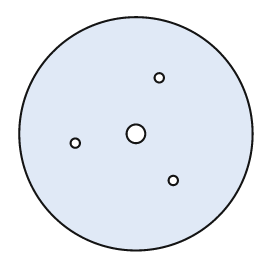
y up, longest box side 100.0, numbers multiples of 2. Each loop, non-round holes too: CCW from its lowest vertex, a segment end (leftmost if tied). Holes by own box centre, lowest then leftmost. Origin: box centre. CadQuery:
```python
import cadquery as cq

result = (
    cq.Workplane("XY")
    .moveTo(0.0, 0.0)
    .circle(50.0)
    .moveTo(16.0, -20.0)
    .circle(2.0)
    .moveTo(-26.0, -4.0)
    .circle(2.0)
    .moveTo(0.0, 0.0)
    .circle(4.0)
    .moveTo(10.0, 24.0)
    .circle(2.0)
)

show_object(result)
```